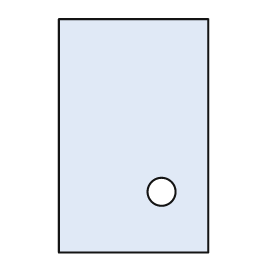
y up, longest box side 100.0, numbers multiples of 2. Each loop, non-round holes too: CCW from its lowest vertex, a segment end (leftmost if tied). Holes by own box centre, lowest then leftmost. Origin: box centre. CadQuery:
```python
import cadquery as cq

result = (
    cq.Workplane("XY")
    .moveTo(-32.0, -50.0)
    .lineTo(32.0, -50.0)
    .lineTo(32.0, 50.0)
    .lineTo(-32.0, 50.0)
    .close()
    .moveTo(12.0, -24.0)
    .circle(6.0)
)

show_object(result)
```